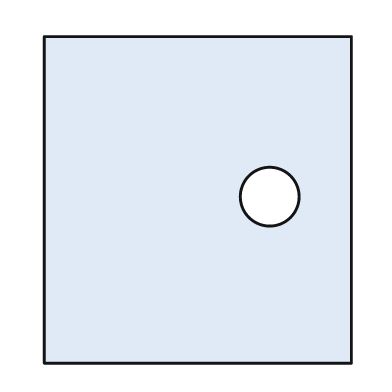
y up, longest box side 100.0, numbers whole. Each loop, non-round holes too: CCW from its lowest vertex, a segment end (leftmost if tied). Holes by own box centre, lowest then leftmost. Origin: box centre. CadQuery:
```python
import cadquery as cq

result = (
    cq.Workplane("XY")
    .moveTo(-47.0, -50.0)
    .lineTo(47.0, -50.0)
    .lineTo(47.0, 50.0)
    .lineTo(-47.0, 50.0)
    .close()
    .moveTo(22.0, 1.0)
    .circle(9.0)
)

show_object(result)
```